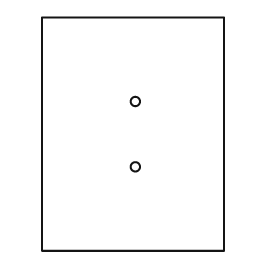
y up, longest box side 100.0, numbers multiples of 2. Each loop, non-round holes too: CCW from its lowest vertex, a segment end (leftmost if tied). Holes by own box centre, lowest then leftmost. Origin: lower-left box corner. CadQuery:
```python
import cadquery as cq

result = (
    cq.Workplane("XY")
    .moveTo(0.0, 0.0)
    .lineTo(78.0, 0.0)
    .lineTo(78.0, 100.0)
    .lineTo(0.0, 100.0)
    .close()
    .moveTo(40.0, 36.0)
    .circle(2.0)
    .moveTo(40.0, 64.0)
    .circle(2.0)
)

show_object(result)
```